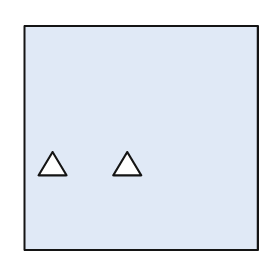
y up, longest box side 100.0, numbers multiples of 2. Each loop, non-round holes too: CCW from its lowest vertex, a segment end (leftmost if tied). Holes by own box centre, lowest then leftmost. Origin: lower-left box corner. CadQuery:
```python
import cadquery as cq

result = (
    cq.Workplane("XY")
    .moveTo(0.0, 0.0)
    .lineTo(100.0, 0.0)
    .lineTo(100.0, 96.0)
    .lineTo(0.0, 96.0)
    .close()
    .moveTo(6.0, 32.0)
    .lineTo(18.0, 32.0)
    .lineTo(12.0, 42.0)
    .close()
    .moveTo(38.0, 32.0)
    .lineTo(50.0, 32.0)
    .lineTo(44.0, 42.0)
    .close()
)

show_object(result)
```